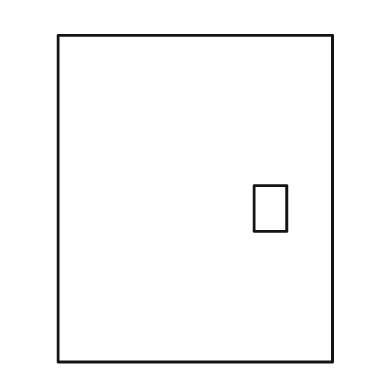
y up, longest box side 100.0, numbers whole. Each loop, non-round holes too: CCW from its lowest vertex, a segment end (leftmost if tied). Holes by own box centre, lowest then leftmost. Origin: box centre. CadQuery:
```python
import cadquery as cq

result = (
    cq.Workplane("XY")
    .moveTo(-42.0, -50.0)
    .lineTo(42.0, -50.0)
    .lineTo(42.0, 50.0)
    .lineTo(-42.0, 50.0)
    .close()
    .moveTo(18.0, -10.0)
    .lineTo(28.0, -10.0)
    .lineTo(28.0, 4.0)
    .lineTo(18.0, 4.0)
    .close()
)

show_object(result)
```